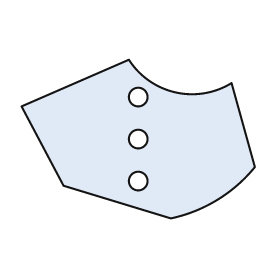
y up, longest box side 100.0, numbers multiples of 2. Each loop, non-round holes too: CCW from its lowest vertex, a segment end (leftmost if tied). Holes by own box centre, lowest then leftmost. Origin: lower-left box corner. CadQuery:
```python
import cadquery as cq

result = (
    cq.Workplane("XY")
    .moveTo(64.0, 0.0)
    .threePointArc((84.0, 8.0), (100.0, 22.0))
    .lineTo(90.0, 58.0)
    .threePointArc((66.0, 54.0), (46.0, 68.0))
    .lineTo(0.0, 48.0)
    .lineTo(18.0, 14.0)
    .close()
    .moveTo(50.0, 16.0)
    .circle(4.0)
    .moveTo(50.0, 34.0)
    .circle(4.0)
    .moveTo(50.0, 52.0)
    .circle(4.0)
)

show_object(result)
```